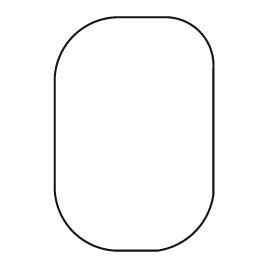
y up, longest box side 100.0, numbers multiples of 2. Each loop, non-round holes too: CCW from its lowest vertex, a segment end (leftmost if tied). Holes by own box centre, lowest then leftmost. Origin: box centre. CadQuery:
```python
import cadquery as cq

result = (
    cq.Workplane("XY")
    .moveTo(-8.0, -50.0)
    .lineTo(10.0, -50.0)
    .threePointArc((26.0, -42.0), (34.0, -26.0))
    .lineTo(34.0, 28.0)
    .threePointArc((28.0, 44.0), (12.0, 50.0))
    .lineTo(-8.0, 50.0)
    .threePointArc((-26.0, 42.0), (-34.0, 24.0))
    .lineTo(-34.0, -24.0)
    .threePointArc((-26.0, -42.0), (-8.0, -50.0))
    .close()
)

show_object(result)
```